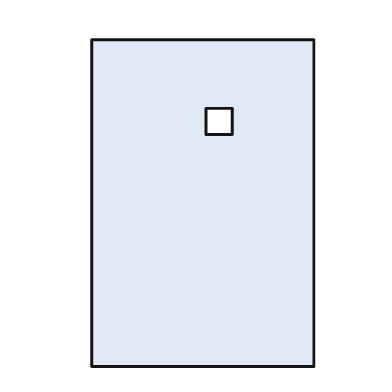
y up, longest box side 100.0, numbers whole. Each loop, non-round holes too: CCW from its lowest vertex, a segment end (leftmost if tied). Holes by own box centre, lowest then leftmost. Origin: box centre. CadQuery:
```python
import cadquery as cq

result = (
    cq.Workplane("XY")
    .moveTo(-34.0, -50.0)
    .lineTo(34.0, -50.0)
    .lineTo(34.0, 50.0)
    .lineTo(-34.0, 50.0)
    .close()
    .moveTo(1.0, 21.0)
    .lineTo(9.0, 21.0)
    .lineTo(9.0, 29.0)
    .lineTo(1.0, 29.0)
    .close()
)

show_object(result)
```